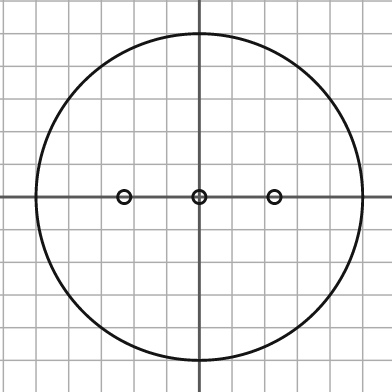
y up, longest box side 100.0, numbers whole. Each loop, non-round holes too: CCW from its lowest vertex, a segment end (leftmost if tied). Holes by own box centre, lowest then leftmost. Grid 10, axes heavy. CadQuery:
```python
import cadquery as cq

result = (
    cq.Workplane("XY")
    .moveTo(0.0, 0.0)
    .circle(50.0)
    .moveTo(-23.0, 0.0)
    .circle(2.0)
    .moveTo(0.0, 0.0)
    .circle(2.0)
    .moveTo(23.0, 0.0)
    .circle(2.0)
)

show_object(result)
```